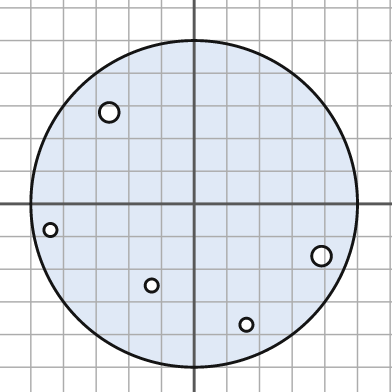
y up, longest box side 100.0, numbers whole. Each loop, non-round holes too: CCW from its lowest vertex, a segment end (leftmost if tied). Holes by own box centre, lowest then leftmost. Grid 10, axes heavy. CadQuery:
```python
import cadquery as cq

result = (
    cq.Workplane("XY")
    .moveTo(0.0, 0.0)
    .circle(50.0)
    .moveTo(16.0, -37.0)
    .circle(2.0)
    .moveTo(-13.0, -25.0)
    .circle(2.0)
    .moveTo(39.0, -16.0)
    .circle(3.0)
    .moveTo(-44.0, -8.0)
    .circle(2.0)
    .moveTo(-26.0, 28.0)
    .circle(3.0)
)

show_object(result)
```